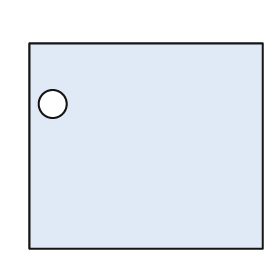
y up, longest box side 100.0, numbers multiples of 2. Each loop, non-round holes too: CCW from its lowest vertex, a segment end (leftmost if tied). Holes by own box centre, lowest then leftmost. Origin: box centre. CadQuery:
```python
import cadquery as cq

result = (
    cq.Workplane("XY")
    .moveTo(-50.0, -44.0)
    .lineTo(50.0, -44.0)
    .lineTo(50.0, 44.0)
    .lineTo(-50.0, 44.0)
    .close()
    .moveTo(-40.0, 18.0)
    .circle(6.0)
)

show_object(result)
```